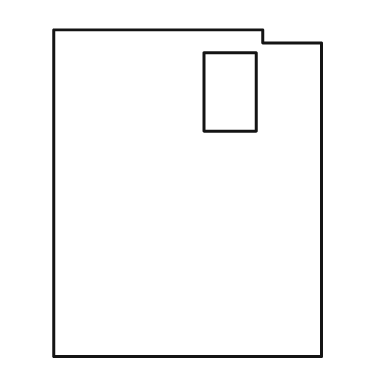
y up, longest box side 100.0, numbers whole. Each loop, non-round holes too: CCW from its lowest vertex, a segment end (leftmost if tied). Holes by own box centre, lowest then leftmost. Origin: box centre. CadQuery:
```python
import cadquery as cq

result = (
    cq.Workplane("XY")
    .moveTo(-41.0, -50.0)
    .lineTo(41.0, -50.0)
    .lineTo(41.0, 46.0)
    .lineTo(23.0, 46.0)
    .lineTo(23.0, 50.0)
    .lineTo(-41.0, 50.0)
    .close()
    .moveTo(5.0, 19.0)
    .lineTo(21.0, 19.0)
    .lineTo(21.0, 43.0)
    .lineTo(5.0, 43.0)
    .close()
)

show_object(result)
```